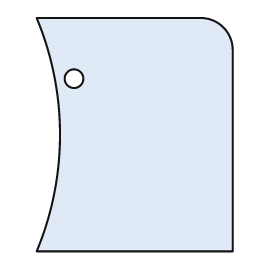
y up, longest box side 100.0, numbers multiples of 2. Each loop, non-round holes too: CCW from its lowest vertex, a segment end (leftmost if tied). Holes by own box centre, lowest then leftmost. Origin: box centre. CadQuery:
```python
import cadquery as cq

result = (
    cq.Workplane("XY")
    .moveTo(-42.0, -50.0)
    .lineTo(42.0, -50.0)
    .lineTo(42.0, 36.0)
    .threePointArc((38.0, 46.0), (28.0, 50.0))
    .lineTo(-42.0, 50.0)
    .threePointArc((-32.0, 0.0), (-42.0, -50.0))
    .close()
    .moveTo(-26.0, 24.0)
    .circle(4.0)
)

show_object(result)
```